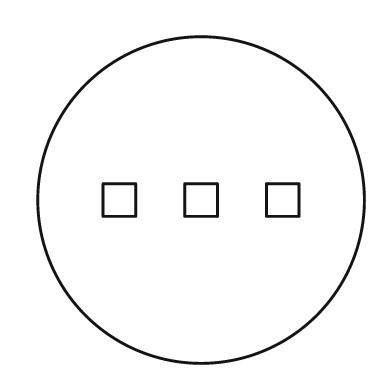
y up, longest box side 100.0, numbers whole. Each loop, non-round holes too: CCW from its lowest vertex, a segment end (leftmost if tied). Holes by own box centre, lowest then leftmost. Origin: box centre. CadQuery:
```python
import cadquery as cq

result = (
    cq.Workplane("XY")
    .moveTo(0.0, 0.0)
    .circle(50.0)
    .moveTo(-30.0, -5.0)
    .lineTo(-20.0, -5.0)
    .lineTo(-20.0, 5.0)
    .lineTo(-30.0, 5.0)
    .close()
    .moveTo(-5.0, -5.0)
    .lineTo(5.0, -5.0)
    .lineTo(5.0, 5.0)
    .lineTo(-5.0, 5.0)
    .close()
    .moveTo(20.0, -5.0)
    .lineTo(30.0, -5.0)
    .lineTo(30.0, 5.0)
    .lineTo(20.0, 5.0)
    .close()
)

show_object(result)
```